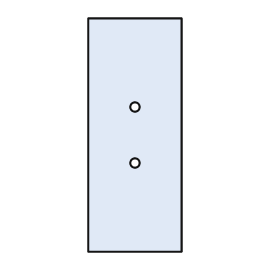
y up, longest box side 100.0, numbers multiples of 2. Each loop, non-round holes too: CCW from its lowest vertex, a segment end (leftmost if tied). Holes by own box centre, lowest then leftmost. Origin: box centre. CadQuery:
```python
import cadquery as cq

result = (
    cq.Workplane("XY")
    .moveTo(-20.0, -50.0)
    .lineTo(20.0, -50.0)
    .lineTo(20.0, 50.0)
    .lineTo(-20.0, 50.0)
    .close()
    .moveTo(0.0, -12.0)
    .circle(2.0)
    .moveTo(0.0, 12.0)
    .circle(2.0)
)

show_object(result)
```